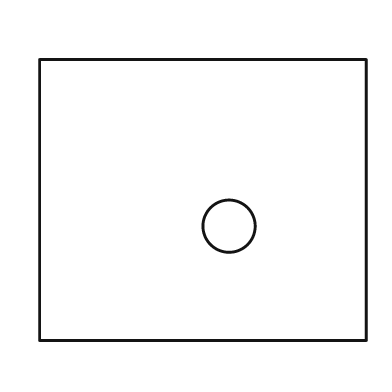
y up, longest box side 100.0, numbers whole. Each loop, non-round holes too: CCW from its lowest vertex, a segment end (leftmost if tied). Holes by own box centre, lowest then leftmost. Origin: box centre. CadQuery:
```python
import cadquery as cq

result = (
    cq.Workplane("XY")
    .moveTo(-50.0, -43.0)
    .lineTo(50.0, -43.0)
    .lineTo(50.0, 43.0)
    .lineTo(-50.0, 43.0)
    .close()
    .moveTo(8.0, -8.0)
    .circle(8.0)
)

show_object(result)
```